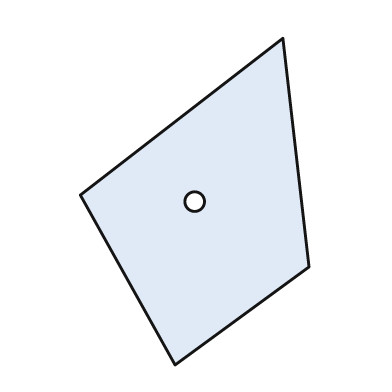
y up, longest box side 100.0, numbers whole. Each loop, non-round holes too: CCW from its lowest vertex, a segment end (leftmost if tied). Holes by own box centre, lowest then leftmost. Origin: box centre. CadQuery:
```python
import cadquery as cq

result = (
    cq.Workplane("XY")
    .moveTo(-6.0, -50.0)
    .lineTo(35.0, -20.0)
    .lineTo(27.0, 50.0)
    .lineTo(-35.0, 2.0)
    .close()
    .moveTo(0.0, 0.0)
    .circle(3.0)
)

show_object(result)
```